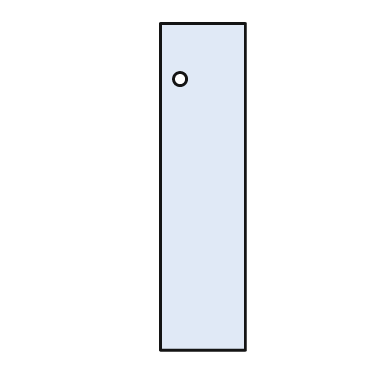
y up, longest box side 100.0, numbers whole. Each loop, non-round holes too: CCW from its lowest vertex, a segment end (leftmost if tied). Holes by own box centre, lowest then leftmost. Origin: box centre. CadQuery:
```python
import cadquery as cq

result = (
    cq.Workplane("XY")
    .moveTo(-13.0, -50.0)
    .lineTo(13.0, -50.0)
    .lineTo(13.0, 50.0)
    .lineTo(-13.0, 50.0)
    .close()
    .moveTo(-7.0, 33.0)
    .circle(2.0)
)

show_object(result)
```